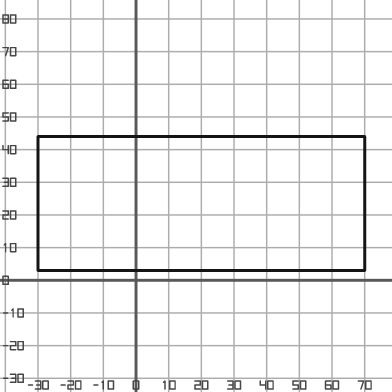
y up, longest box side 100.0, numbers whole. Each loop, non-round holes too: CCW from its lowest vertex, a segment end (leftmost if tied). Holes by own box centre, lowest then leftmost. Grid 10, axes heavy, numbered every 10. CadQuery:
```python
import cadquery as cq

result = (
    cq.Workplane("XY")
    .moveTo(-30.0, 3.0)
    .lineTo(70.0, 3.0)
    .lineTo(70.0, 44.0)
    .lineTo(-30.0, 44.0)
    .close()
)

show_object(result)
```